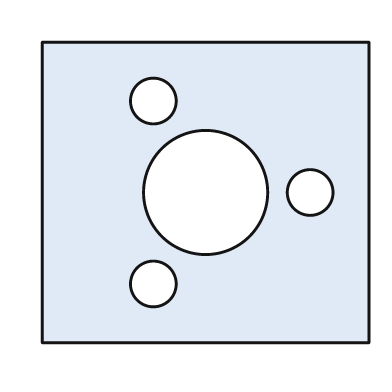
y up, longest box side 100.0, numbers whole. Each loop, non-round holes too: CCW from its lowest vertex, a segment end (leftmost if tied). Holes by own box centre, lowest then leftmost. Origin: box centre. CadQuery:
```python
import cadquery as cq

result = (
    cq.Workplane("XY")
    .moveTo(-50.0, -46.0)
    .lineTo(50.0, -46.0)
    .lineTo(50.0, 46.0)
    .lineTo(-50.0, 46.0)
    .close()
    .moveTo(-16.0, -28.0)
    .circle(7.0)
    .moveTo(0.0, 0.0)
    .circle(19.0)
    .moveTo(32.0, 0.0)
    .circle(7.0)
    .moveTo(-16.0, 28.0)
    .circle(7.0)
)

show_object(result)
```